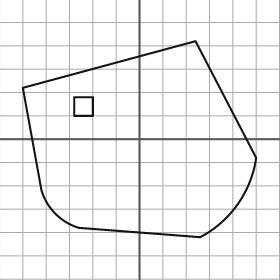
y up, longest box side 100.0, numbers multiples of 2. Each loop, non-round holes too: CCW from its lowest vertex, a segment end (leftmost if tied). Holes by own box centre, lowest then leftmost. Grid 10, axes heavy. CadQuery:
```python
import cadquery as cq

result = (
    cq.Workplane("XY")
    .moveTo(26.0, -42.0)
    .threePointArc((42.0, -28.0), (50.0, -8.0))
    .lineTo(24.0, 42.0)
    .lineTo(-50.0, 22.0)
    .lineTo(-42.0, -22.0)
    .threePointArc((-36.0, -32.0), (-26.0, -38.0))
    .close()
    .moveTo(-28.0, 10.0)
    .lineTo(-20.0, 10.0)
    .lineTo(-20.0, 18.0)
    .lineTo(-28.0, 18.0)
    .close()
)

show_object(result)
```